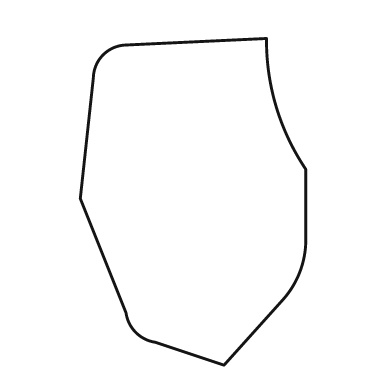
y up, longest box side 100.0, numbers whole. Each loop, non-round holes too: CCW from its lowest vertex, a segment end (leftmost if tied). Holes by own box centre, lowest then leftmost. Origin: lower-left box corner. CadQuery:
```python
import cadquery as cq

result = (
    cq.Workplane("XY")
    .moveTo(44.0, 0.0)
    .lineTo(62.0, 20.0)
    .threePointArc((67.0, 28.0), (69.0, 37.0))
    .lineTo(69.0, 60.0)
    .threePointArc((60.0, 79.0), (57.0, 100.0))
    .lineTo(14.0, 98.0)
    .threePointArc((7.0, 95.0), (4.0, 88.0))
    .lineTo(0.0, 51.0)
    .lineTo(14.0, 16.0)
    .threePointArc((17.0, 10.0), (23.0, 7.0))
    .close()
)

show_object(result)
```